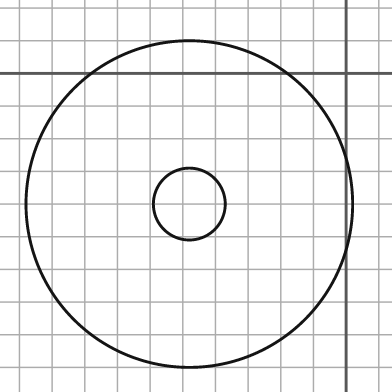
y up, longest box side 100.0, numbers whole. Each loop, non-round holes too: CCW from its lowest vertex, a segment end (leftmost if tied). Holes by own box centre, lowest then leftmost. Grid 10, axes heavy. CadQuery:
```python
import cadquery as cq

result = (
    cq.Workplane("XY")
    .moveTo(-48.0, -40.0)
    .circle(50.0)
    .moveTo(-48.0, -40.0)
    .circle(11.0)
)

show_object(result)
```